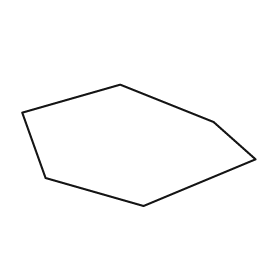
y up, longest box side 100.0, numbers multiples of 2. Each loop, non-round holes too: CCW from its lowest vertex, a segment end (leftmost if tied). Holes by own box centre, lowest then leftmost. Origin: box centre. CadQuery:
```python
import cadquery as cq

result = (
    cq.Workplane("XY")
    .moveTo(2.0, -26.0)
    .lineTo(50.0, -6.0)
    .lineTo(32.0, 10.0)
    .lineTo(-8.0, 26.0)
    .lineTo(-50.0, 14.0)
    .lineTo(-40.0, -14.0)
    .close()
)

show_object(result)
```